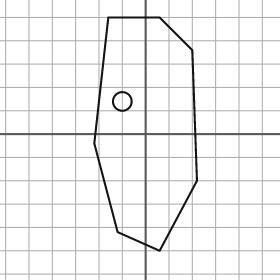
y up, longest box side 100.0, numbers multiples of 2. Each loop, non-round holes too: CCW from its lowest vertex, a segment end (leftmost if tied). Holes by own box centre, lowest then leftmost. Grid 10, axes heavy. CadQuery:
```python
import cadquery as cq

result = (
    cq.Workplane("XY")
    .moveTo(6.0, -50.0)
    .lineTo(22.0, -20.0)
    .lineTo(20.0, 36.0)
    .lineTo(6.0, 50.0)
    .lineTo(-16.0, 50.0)
    .lineTo(-22.0, -4.0)
    .lineTo(-12.0, -42.0)
    .close()
    .moveTo(-10.0, 14.0)
    .circle(4.0)
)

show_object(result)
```